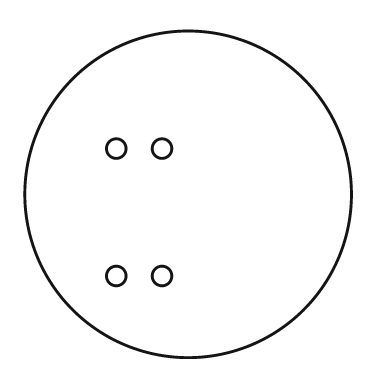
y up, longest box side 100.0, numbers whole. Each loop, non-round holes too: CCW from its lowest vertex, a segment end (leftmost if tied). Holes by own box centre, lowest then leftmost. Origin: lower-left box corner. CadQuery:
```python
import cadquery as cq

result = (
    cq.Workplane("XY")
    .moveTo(50.0, 50.0)
    .circle(50.0)
    .moveTo(28.0, 25.0)
    .circle(3.0)
    .moveTo(42.0, 25.0)
    .circle(3.0)
    .moveTo(28.0, 64.0)
    .circle(3.0)
    .moveTo(42.0, 64.0)
    .circle(3.0)
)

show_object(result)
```